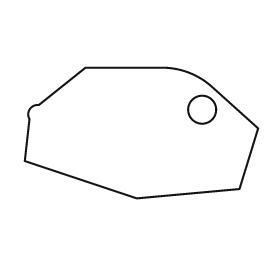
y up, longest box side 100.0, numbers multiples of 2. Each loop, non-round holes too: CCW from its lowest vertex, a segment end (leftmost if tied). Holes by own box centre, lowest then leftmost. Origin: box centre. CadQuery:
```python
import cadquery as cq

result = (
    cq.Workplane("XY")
    .moveTo(-2.0, -28.0)
    .lineTo(42.0, -24.0)
    .lineTo(50.0, 2.0)
    .lineTo(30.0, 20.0)
    .threePointArc((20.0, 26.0), (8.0, 28.0))
    .lineTo(-24.0, 28.0)
    .lineTo(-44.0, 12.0)
    .threePointArc((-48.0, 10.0), (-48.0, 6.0))
    .lineTo(-50.0, -12.0)
    .close()
    .moveTo(26.0, 10.0)
    .circle(6.0)
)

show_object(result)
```